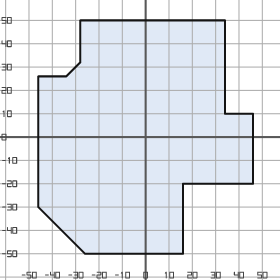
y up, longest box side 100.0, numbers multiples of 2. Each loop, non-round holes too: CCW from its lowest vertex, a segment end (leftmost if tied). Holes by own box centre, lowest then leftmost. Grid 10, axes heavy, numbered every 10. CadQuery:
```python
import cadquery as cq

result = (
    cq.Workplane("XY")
    .moveTo(-26.0, -50.0)
    .lineTo(16.0, -50.0)
    .lineTo(16.0, -20.0)
    .lineTo(46.0, -20.0)
    .lineTo(46.0, 10.0)
    .lineTo(34.0, 10.0)
    .lineTo(34.0, 50.0)
    .lineTo(-28.0, 50.0)
    .lineTo(-28.0, 32.0)
    .lineTo(-34.0, 26.0)
    .lineTo(-46.0, 26.0)
    .lineTo(-46.0, -30.0)
    .close()
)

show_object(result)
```